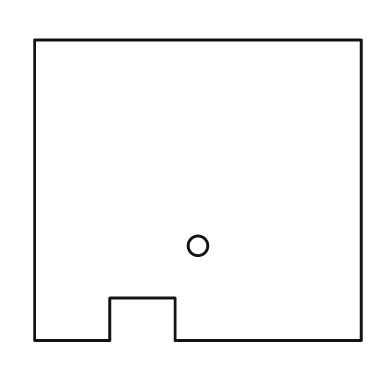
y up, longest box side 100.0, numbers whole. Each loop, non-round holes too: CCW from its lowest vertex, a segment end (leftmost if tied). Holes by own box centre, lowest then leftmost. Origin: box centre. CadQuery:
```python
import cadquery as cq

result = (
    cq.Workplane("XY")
    .moveTo(-50.0, -46.0)
    .lineTo(-27.0, -46.0)
    .lineTo(-27.0, -33.0)
    .lineTo(-7.0, -33.0)
    .lineTo(-7.0, -46.0)
    .lineTo(50.0, -46.0)
    .lineTo(50.0, 46.0)
    .lineTo(-50.0, 46.0)
    .close()
    .moveTo(0.0, -17.0)
    .circle(3.0)
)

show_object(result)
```